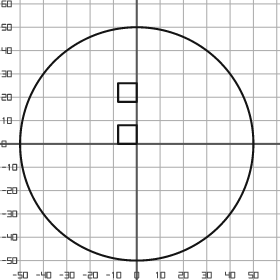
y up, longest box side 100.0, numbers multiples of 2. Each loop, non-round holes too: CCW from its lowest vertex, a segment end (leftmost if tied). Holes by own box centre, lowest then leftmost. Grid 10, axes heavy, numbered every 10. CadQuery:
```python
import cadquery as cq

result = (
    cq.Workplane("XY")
    .moveTo(0.0, 0.0)
    .circle(50.0)
    .moveTo(-8.0, 0.0)
    .lineTo(0.0, 0.0)
    .lineTo(0.0, 8.0)
    .lineTo(-8.0, 8.0)
    .close()
    .moveTo(-8.0, 18.0)
    .lineTo(0.0, 18.0)
    .lineTo(0.0, 26.0)
    .lineTo(-8.0, 26.0)
    .close()
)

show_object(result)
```